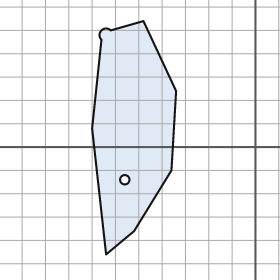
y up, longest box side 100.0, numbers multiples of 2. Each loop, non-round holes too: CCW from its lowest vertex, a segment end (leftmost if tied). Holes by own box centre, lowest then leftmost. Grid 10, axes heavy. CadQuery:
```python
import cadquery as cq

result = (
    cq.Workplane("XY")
    .moveTo(-64.0, -46.0)
    .lineTo(-52.0, -36.0)
    .lineTo(-36.0, -10.0)
    .lineTo(-34.0, 24.0)
    .lineTo(-48.0, 54.0)
    .lineTo(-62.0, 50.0)
    .threePointArc((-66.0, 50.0), (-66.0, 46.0))
    .lineTo(-70.0, 8.0)
    .close()
    .moveTo(-56.0, -14.0)
    .circle(2.0)
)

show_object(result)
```